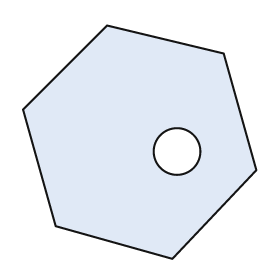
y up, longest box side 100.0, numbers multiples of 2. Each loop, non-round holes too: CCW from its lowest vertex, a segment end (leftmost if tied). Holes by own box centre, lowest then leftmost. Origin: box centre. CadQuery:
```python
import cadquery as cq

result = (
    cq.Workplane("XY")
    .moveTo(14.0, -50.0)
    .lineTo(50.0, -12.0)
    .lineTo(36.0, 38.0)
    .lineTo(-14.0, 50.0)
    .lineTo(-50.0, 14.0)
    .lineTo(-36.0, -36.0)
    .close()
    .moveTo(16.0, -4.0)
    .circle(10.0)
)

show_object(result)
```